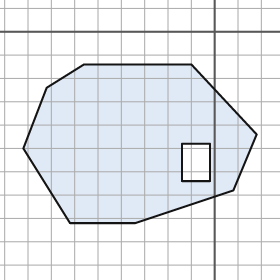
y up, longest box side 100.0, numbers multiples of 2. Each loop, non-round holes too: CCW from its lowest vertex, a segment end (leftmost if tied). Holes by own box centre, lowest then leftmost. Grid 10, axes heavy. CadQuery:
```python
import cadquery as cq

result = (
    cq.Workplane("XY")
    .moveTo(-62.0, -82.0)
    .lineTo(-34.0, -82.0)
    .lineTo(8.0, -68.0)
    .lineTo(18.0, -44.0)
    .lineTo(-10.0, -14.0)
    .lineTo(-56.0, -14.0)
    .lineTo(-72.0, -24.0)
    .lineTo(-82.0, -50.0)
    .close()
    .moveTo(-14.0, -64.0)
    .lineTo(-2.0, -64.0)
    .lineTo(-2.0, -48.0)
    .lineTo(-14.0, -48.0)
    .close()
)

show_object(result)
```